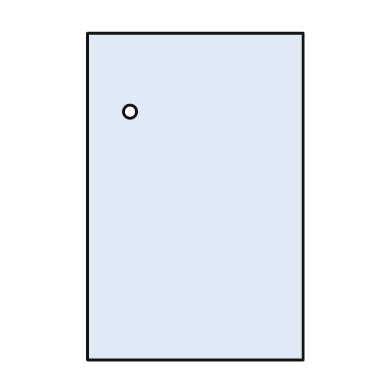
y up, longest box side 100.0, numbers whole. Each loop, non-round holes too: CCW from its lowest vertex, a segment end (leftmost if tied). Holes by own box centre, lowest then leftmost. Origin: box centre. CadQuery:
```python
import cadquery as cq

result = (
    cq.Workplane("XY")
    .moveTo(-33.0, -50.0)
    .lineTo(33.0, -50.0)
    .lineTo(33.0, 50.0)
    .lineTo(-33.0, 50.0)
    .close()
    .moveTo(-20.0, 26.0)
    .circle(2.0)
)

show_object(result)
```